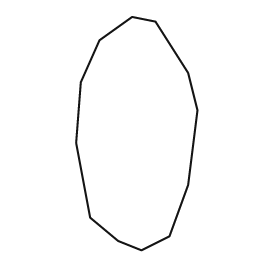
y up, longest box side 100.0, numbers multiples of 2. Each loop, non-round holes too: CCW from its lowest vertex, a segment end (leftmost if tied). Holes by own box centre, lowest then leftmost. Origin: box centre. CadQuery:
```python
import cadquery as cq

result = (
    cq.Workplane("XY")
    .moveTo(2.0, -50.0)
    .lineTo(14.0, -44.0)
    .lineTo(22.0, -22.0)
    .lineTo(26.0, 10.0)
    .lineTo(22.0, 26.0)
    .lineTo(8.0, 48.0)
    .lineTo(-2.0, 50.0)
    .lineTo(-16.0, 40.0)
    .lineTo(-24.0, 22.0)
    .lineTo(-26.0, -4.0)
    .lineTo(-20.0, -36.0)
    .lineTo(-8.0, -46.0)
    .close()
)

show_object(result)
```